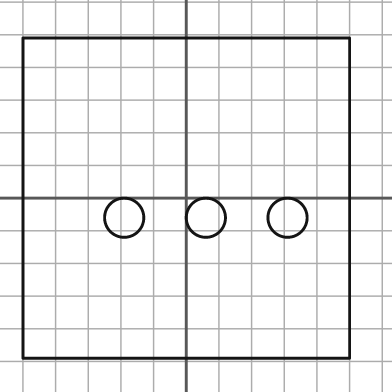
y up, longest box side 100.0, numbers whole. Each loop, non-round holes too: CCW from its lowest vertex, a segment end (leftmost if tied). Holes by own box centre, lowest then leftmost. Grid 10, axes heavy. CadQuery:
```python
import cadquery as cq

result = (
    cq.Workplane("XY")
    .moveTo(-50.0, -49.0)
    .lineTo(50.0, -49.0)
    .lineTo(50.0, 49.0)
    .lineTo(-50.0, 49.0)
    .close()
    .moveTo(-19.0, -6.0)
    .circle(6.0)
    .moveTo(6.0, -6.0)
    .circle(6.0)
    .moveTo(31.0, -6.0)
    .circle(6.0)
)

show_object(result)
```